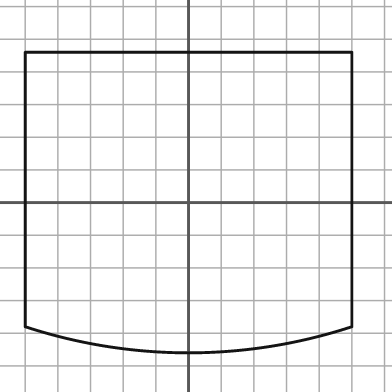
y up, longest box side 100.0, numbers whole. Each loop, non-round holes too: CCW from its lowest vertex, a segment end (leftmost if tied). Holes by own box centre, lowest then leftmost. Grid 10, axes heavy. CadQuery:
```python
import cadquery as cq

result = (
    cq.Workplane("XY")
    .moveTo(-50.0, -38.0)
    .threePointArc((0.0, -46.0), (50.0, -38.0))
    .lineTo(50.0, 46.0)
    .lineTo(-50.0, 46.0)
    .close()
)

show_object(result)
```